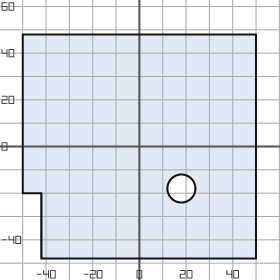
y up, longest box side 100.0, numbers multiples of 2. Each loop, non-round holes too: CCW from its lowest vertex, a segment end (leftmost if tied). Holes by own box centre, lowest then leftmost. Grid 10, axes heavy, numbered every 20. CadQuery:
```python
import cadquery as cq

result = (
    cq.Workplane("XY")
    .moveTo(-42.0, -48.0)
    .lineTo(50.0, -48.0)
    .lineTo(50.0, 48.0)
    .lineTo(-50.0, 48.0)
    .lineTo(-50.0, -20.0)
    .lineTo(-42.0, -20.0)
    .close()
    .moveTo(18.0, -18.0)
    .circle(6.0)
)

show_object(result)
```